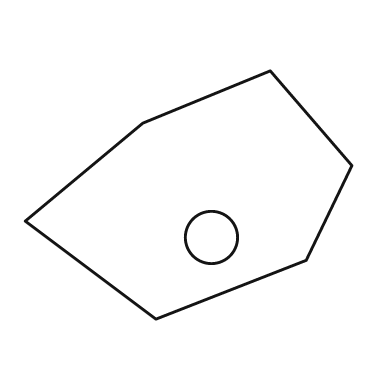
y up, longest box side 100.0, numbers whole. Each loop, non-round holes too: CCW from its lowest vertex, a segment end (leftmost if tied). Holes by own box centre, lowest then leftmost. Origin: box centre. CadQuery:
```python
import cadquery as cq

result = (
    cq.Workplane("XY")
    .moveTo(-10.0, -38.0)
    .lineTo(36.0, -20.0)
    .lineTo(50.0, 9.0)
    .lineTo(25.0, 38.0)
    .lineTo(-14.0, 22.0)
    .lineTo(-50.0, -8.0)
    .close()
    .moveTo(7.0, -13.0)
    .circle(8.0)
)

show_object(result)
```